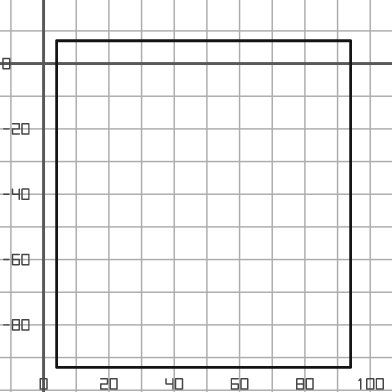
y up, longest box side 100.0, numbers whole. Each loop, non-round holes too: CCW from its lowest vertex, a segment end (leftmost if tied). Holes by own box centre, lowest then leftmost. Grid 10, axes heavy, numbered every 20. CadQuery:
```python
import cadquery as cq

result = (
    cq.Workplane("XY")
    .moveTo(4.0, -93.0)
    .lineTo(94.0, -93.0)
    .lineTo(94.0, 7.0)
    .lineTo(4.0, 7.0)
    .close()
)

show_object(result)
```